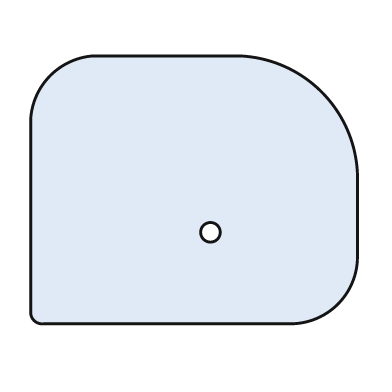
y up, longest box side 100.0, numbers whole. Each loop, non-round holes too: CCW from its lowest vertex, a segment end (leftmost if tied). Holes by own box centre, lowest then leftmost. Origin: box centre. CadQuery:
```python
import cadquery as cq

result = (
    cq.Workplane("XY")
    .moveTo(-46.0, -41.0)
    .lineTo(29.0, -41.0)
    .threePointArc((44.0, -35.0), (50.0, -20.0))
    .lineTo(50.0, 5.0)
    .threePointArc((39.0, 30.0), (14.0, 41.0))
    .lineTo(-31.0, 41.0)
    .threePointArc((-44.0, 35.0), (-50.0, 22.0))
    .lineTo(-50.0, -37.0)
    .threePointArc((-49.0, -40.0), (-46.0, -41.0))
    .close()
    .moveTo(5.0, -13.0)
    .circle(3.0)
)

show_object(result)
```